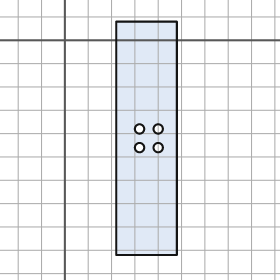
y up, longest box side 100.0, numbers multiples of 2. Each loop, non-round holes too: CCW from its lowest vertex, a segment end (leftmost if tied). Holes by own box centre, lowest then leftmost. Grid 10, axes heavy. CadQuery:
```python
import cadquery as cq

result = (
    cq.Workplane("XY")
    .moveTo(22.0, -92.0)
    .lineTo(48.0, -92.0)
    .lineTo(48.0, 8.0)
    .lineTo(22.0, 8.0)
    .close()
    .moveTo(32.0, -46.0)
    .circle(2.0)
    .moveTo(40.0, -46.0)
    .circle(2.0)
    .moveTo(32.0, -38.0)
    .circle(2.0)
    .moveTo(40.0, -38.0)
    .circle(2.0)
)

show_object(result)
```